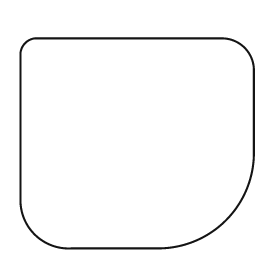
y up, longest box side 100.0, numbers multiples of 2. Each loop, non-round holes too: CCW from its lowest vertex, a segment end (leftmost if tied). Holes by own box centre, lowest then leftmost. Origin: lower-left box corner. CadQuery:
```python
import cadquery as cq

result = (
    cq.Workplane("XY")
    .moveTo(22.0, 0.0)
    .lineTo(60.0, 0.0)
    .threePointArc((88.0, 12.0), (100.0, 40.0))
    .lineTo(100.0, 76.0)
    .threePointArc((96.0, 86.0), (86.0, 90.0))
    .lineTo(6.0, 90.0)
    .threePointArc((2.0, 88.0), (0.0, 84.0))
    .lineTo(0.0, 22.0)
    .threePointArc((6.0, 6.0), (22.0, 0.0))
    .close()
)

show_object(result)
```